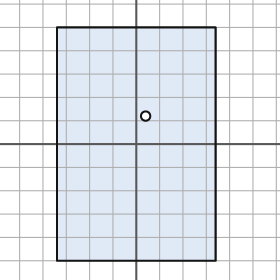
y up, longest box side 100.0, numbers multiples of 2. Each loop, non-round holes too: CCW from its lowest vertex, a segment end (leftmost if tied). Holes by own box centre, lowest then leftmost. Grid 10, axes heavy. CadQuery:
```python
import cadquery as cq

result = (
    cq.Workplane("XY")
    .moveTo(-34.0, -50.0)
    .lineTo(34.0, -50.0)
    .lineTo(34.0, 50.0)
    .lineTo(-34.0, 50.0)
    .close()
    .moveTo(4.0, 12.0)
    .circle(2.0)
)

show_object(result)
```